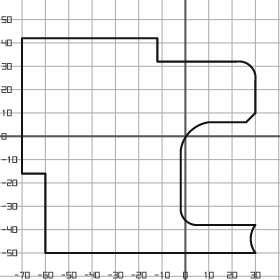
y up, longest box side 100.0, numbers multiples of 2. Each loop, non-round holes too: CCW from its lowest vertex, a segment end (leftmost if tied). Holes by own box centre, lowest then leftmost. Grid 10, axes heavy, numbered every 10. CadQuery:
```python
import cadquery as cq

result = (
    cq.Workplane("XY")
    .moveTo(-60.0, -50.0)
    .lineTo(30.0, -50.0)
    .threePointArc((28.0, -44.0), (30.0, -38.0))
    .lineTo(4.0, -38.0)
    .threePointArc((0.0, -36.0), (-2.0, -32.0))
    .lineTo(-2.0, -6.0)
    .threePointArc((2.0, 2.0), (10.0, 6.0))
    .lineTo(26.0, 6.0)
    .lineTo(30.0, 10.0)
    .lineTo(30.0, 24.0)
    .threePointArc((28.0, 30.0), (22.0, 32.0))
    .lineTo(-12.0, 32.0)
    .lineTo(-12.0, 42.0)
    .lineTo(-70.0, 42.0)
    .lineTo(-70.0, -16.0)
    .lineTo(-60.0, -16.0)
    .close()
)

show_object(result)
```